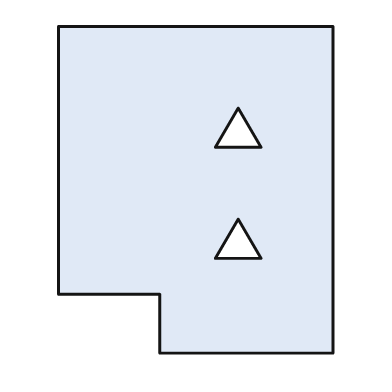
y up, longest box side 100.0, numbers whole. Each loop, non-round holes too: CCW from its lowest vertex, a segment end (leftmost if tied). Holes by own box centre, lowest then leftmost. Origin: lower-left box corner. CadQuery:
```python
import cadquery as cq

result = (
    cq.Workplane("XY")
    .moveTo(31.0, 0.0)
    .lineTo(84.0, 0.0)
    .lineTo(84.0, 100.0)
    .lineTo(0.0, 100.0)
    .lineTo(0.0, 18.0)
    .lineTo(31.0, 18.0)
    .close()
    .moveTo(48.0, 29.0)
    .lineTo(62.0, 29.0)
    .lineTo(55.0, 41.0)
    .close()
    .moveTo(48.0, 63.0)
    .lineTo(62.0, 63.0)
    .lineTo(55.0, 75.0)
    .close()
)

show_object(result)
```